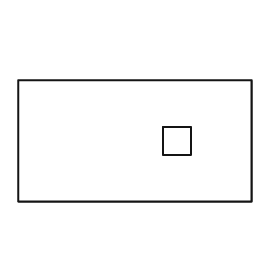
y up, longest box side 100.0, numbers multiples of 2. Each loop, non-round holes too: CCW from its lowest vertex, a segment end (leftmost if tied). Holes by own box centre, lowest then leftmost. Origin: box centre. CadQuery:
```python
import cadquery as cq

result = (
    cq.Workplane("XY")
    .moveTo(-50.0, -26.0)
    .lineTo(50.0, -26.0)
    .lineTo(50.0, 26.0)
    .lineTo(-50.0, 26.0)
    .close()
    .moveTo(12.0, -6.0)
    .lineTo(24.0, -6.0)
    .lineTo(24.0, 6.0)
    .lineTo(12.0, 6.0)
    .close()
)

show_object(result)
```